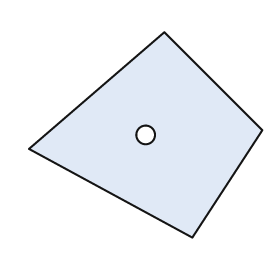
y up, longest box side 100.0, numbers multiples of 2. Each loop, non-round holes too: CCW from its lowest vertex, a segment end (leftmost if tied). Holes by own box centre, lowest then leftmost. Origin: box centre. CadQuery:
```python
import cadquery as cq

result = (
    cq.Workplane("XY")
    .moveTo(20.0, -44.0)
    .lineTo(50.0, 2.0)
    .lineTo(8.0, 44.0)
    .lineTo(-50.0, -6.0)
    .close()
    .moveTo(0.0, 0.0)
    .circle(4.0)
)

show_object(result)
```